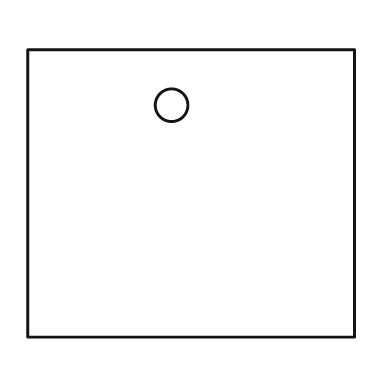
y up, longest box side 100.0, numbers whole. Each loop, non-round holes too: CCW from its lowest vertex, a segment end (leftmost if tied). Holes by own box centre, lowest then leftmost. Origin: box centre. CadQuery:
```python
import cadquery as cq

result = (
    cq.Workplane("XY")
    .moveTo(-50.0, -44.0)
    .lineTo(50.0, -44.0)
    .lineTo(50.0, 44.0)
    .lineTo(-50.0, 44.0)
    .close()
    .moveTo(-6.0, 27.0)
    .circle(5.0)
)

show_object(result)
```